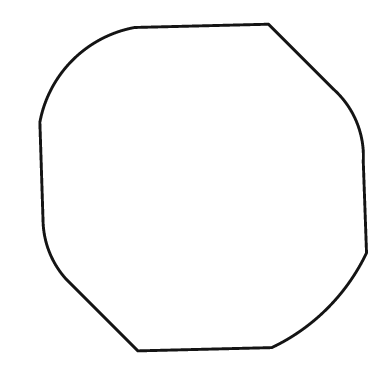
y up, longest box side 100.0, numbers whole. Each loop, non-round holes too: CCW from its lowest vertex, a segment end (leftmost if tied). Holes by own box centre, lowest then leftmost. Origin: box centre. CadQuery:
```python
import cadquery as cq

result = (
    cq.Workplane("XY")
    .moveTo(-20.0, -50.0)
    .lineTo(21.0, -49.0)
    .threePointArc((38.0, -37.0), (50.0, -20.0))
    .lineTo(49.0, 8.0)
    .threePointArc((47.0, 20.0), (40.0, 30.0))
    .lineTo(20.0, 50.0)
    .lineTo(-21.0, 49.0)
    .threePointArc((-40.0, 39.0), (-50.0, 20.0))
    .lineTo(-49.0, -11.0)
    .threePointArc((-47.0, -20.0), (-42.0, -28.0))
    .close()
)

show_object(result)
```